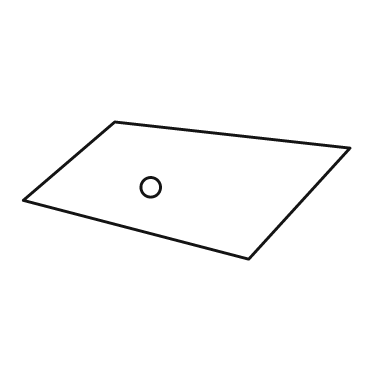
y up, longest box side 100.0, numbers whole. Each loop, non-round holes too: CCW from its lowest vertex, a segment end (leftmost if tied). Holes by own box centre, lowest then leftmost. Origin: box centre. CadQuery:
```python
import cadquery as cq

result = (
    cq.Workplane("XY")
    .moveTo(19.0, -21.0)
    .lineTo(50.0, 13.0)
    .lineTo(-22.0, 21.0)
    .lineTo(-50.0, -3.0)
    .close()
    .moveTo(-11.0, 1.0)
    .circle(3.0)
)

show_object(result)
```